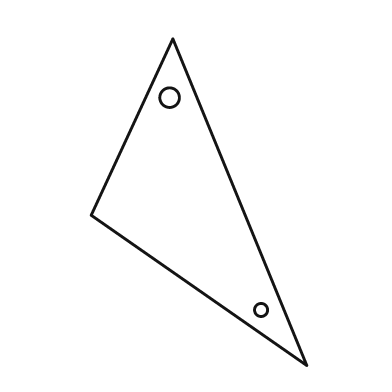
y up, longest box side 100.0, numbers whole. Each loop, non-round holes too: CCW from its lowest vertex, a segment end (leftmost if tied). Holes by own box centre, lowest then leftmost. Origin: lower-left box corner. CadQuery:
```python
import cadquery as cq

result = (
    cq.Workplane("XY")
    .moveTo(66.0, 0.0)
    .lineTo(25.0, 100.0)
    .lineTo(0.0, 46.0)
    .close()
    .moveTo(52.0, 17.0)
    .circle(2.0)
    .moveTo(24.0, 82.0)
    .circle(3.0)
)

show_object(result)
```